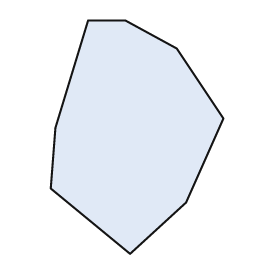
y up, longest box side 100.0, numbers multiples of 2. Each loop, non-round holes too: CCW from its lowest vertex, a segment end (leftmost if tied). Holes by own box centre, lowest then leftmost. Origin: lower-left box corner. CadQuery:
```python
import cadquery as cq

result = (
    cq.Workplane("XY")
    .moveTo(34.0, 0.0)
    .lineTo(58.0, 22.0)
    .lineTo(74.0, 58.0)
    .lineTo(54.0, 88.0)
    .lineTo(32.0, 100.0)
    .lineTo(16.0, 100.0)
    .lineTo(2.0, 54.0)
    .lineTo(0.0, 28.0)
    .close()
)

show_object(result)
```